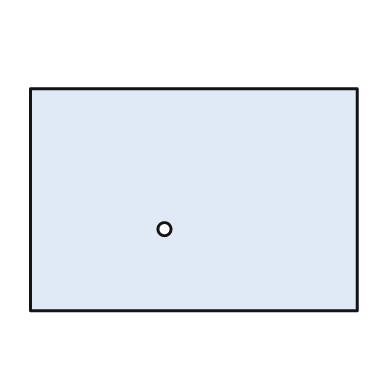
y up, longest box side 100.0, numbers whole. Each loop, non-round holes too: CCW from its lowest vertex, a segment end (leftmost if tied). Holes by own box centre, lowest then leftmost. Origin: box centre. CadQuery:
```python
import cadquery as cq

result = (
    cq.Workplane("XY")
    .moveTo(-50.0, -34.0)
    .lineTo(50.0, -34.0)
    .lineTo(50.0, 34.0)
    .lineTo(-50.0, 34.0)
    .close()
    .moveTo(-9.0, -9.0)
    .circle(2.0)
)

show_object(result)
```